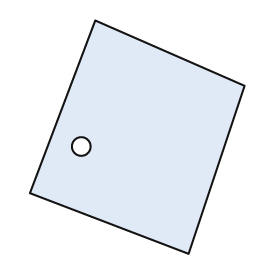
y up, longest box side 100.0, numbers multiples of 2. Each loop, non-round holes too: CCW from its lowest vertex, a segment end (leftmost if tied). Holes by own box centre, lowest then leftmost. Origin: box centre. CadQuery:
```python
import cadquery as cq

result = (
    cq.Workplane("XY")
    .moveTo(22.0, -50.0)
    .lineTo(46.0, 22.0)
    .lineTo(-18.0, 50.0)
    .lineTo(-46.0, -24.0)
    .close()
    .moveTo(-24.0, -4.0)
    .circle(4.0)
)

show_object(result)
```